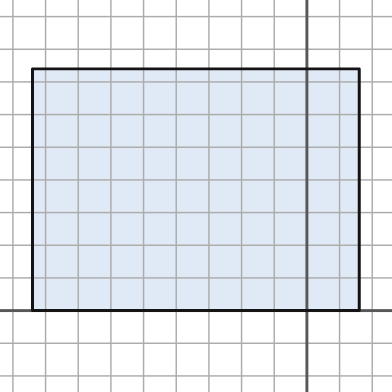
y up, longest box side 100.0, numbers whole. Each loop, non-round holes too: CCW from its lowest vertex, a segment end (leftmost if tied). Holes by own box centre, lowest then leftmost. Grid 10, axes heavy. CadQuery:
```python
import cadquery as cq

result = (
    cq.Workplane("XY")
    .moveTo(-84.0, 0.0)
    .lineTo(16.0, 0.0)
    .lineTo(16.0, 74.0)
    .lineTo(-84.0, 74.0)
    .close()
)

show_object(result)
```